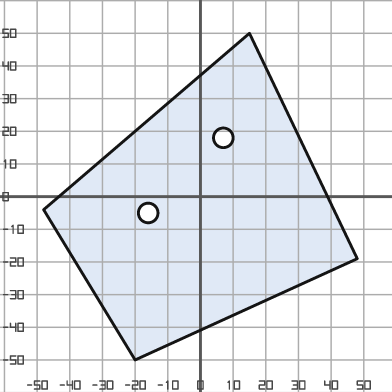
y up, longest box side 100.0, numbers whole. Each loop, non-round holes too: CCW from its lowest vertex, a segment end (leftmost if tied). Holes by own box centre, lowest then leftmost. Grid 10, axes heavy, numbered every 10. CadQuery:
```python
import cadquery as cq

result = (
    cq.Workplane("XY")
    .moveTo(-20.0, -50.0)
    .lineTo(48.0, -19.0)
    .lineTo(15.0, 50.0)
    .lineTo(-48.0, -4.0)
    .close()
    .moveTo(-16.0, -5.0)
    .circle(3.0)
    .moveTo(7.0, 18.0)
    .circle(3.0)
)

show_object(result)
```